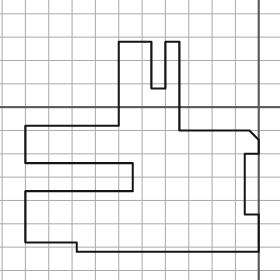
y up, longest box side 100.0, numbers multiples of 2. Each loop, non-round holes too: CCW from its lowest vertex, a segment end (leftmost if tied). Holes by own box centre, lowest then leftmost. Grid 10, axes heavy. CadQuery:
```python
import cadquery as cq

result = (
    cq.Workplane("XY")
    .moveTo(-78.0, -62.0)
    .lineTo(0.0, -62.0)
    .lineTo(0.0, -46.0)
    .lineTo(-6.0, -46.0)
    .lineTo(-6.0, -20.0)
    .lineTo(0.0, -20.0)
    .lineTo(0.0, -14.0)
    .lineTo(-4.0, -10.0)
    .lineTo(-34.0, -10.0)
    .lineTo(-34.0, 28.0)
    .lineTo(-40.0, 28.0)
    .lineTo(-40.0, 8.0)
    .lineTo(-46.0, 8.0)
    .lineTo(-46.0, 28.0)
    .lineTo(-60.0, 28.0)
    .lineTo(-60.0, -8.0)
    .lineTo(-100.0, -8.0)
    .lineTo(-100.0, -24.0)
    .lineTo(-54.0, -24.0)
    .lineTo(-54.0, -36.0)
    .lineTo(-100.0, -36.0)
    .lineTo(-100.0, -58.0)
    .lineTo(-78.0, -58.0)
    .close()
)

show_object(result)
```